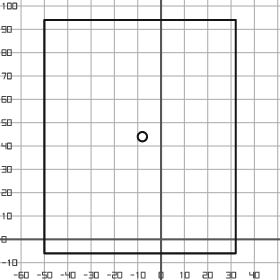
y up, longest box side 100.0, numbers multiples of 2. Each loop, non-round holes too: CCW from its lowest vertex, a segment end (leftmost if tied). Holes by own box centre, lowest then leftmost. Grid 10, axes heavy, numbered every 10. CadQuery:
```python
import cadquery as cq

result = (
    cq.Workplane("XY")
    .moveTo(-50.0, -6.0)
    .lineTo(32.0, -6.0)
    .lineTo(32.0, 94.0)
    .lineTo(-50.0, 94.0)
    .close()
    .moveTo(-8.0, 44.0)
    .circle(2.0)
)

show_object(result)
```